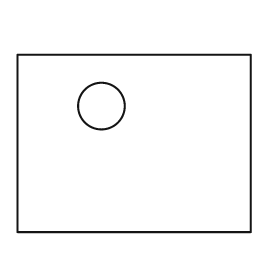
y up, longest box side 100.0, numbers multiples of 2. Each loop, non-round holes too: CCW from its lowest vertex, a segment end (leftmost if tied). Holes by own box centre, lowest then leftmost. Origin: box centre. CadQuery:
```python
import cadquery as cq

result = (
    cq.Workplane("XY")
    .moveTo(-50.0, -38.0)
    .lineTo(50.0, -38.0)
    .lineTo(50.0, 38.0)
    .lineTo(-50.0, 38.0)
    .close()
    .moveTo(-14.0, 16.0)
    .circle(10.0)
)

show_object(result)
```